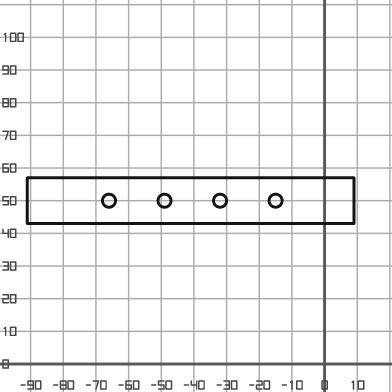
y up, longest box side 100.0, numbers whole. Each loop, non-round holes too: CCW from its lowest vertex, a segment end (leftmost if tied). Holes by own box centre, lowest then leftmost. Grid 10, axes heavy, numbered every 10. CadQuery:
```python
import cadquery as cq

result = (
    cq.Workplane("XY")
    .moveTo(-91.0, 43.0)
    .lineTo(9.0, 43.0)
    .lineTo(9.0, 57.0)
    .lineTo(-91.0, 57.0)
    .close()
    .moveTo(-66.0, 50.0)
    .circle(2.0)
    .moveTo(-49.0, 50.0)
    .circle(2.0)
    .moveTo(-32.0, 50.0)
    .circle(2.0)
    .moveTo(-15.0, 50.0)
    .circle(2.0)
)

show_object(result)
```